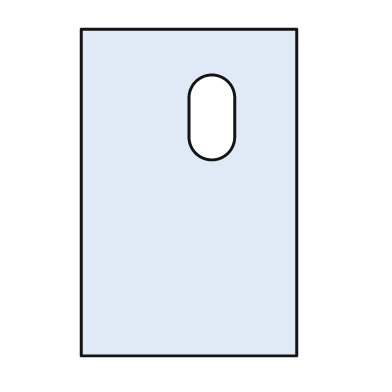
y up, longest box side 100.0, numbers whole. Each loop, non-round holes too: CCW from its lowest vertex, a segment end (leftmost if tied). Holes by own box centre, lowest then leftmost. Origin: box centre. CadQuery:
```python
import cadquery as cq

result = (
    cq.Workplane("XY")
    .moveTo(-33.0, -50.0)
    .lineTo(33.0, -50.0)
    .lineTo(33.0, 50.0)
    .lineTo(-33.0, 50.0)
    .close()
    .moveTo(0.0, 17.0)
    .threePointArc((7.0, 10.0), (14.0, 17.0))
    .lineTo(14.0, 29.0)
    .threePointArc((7.0, 36.0), (0.0, 29.0))
    .close()
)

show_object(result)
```